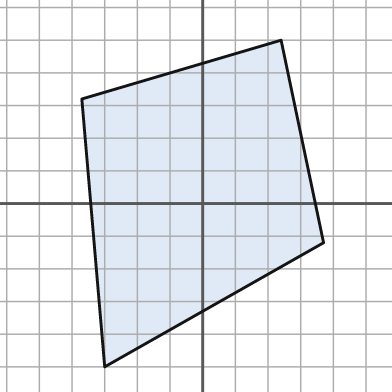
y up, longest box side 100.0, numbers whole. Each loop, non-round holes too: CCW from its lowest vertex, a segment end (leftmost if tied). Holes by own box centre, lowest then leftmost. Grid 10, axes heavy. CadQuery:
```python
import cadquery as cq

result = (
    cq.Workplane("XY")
    .moveTo(-30.0, -50.0)
    .lineTo(37.0, -12.0)
    .lineTo(24.0, 50.0)
    .lineTo(-37.0, 32.0)
    .close()
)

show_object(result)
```